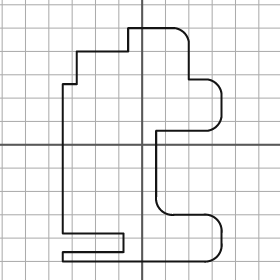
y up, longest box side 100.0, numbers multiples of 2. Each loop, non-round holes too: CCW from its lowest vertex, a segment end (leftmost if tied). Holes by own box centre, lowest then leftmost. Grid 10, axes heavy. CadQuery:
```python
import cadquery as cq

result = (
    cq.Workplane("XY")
    .moveTo(-34.0, -50.0)
    .lineTo(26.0, -50.0)
    .threePointArc((32.0, -48.0), (34.0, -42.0))
    .lineTo(34.0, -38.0)
    .threePointArc((32.0, -32.0), (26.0, -30.0))
    .lineTo(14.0, -30.0)
    .threePointArc((8.0, -28.0), (6.0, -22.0))
    .lineTo(6.0, 6.0)
    .lineTo(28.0, 6.0)
    .threePointArc((32.0, 8.0), (34.0, 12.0))
    .lineTo(34.0, 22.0)
    .threePointArc((32.0, 26.0), (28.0, 28.0))
    .lineTo(20.0, 28.0)
    .lineTo(20.0, 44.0)
    .threePointArc((18.0, 48.0), (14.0, 50.0))
    .lineTo(-6.0, 50.0)
    .lineTo(-6.0, 40.0)
    .lineTo(-28.0, 40.0)
    .lineTo(-28.0, 26.0)
    .lineTo(-34.0, 26.0)
    .lineTo(-34.0, -38.0)
    .lineTo(-8.0, -38.0)
    .lineTo(-8.0, -46.0)
    .lineTo(-34.0, -46.0)
    .close()
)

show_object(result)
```